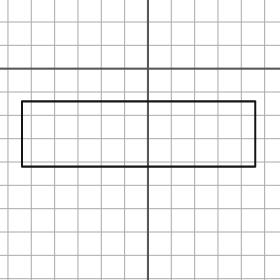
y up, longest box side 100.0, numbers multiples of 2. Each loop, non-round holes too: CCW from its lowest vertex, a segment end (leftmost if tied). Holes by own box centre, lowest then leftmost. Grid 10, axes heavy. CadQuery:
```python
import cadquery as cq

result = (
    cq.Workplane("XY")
    .moveTo(-54.0, -42.0)
    .lineTo(46.0, -42.0)
    .lineTo(46.0, -14.0)
    .lineTo(-54.0, -14.0)
    .close()
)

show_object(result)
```